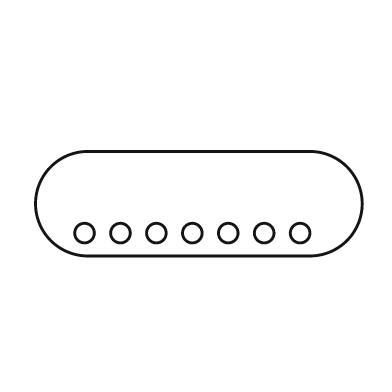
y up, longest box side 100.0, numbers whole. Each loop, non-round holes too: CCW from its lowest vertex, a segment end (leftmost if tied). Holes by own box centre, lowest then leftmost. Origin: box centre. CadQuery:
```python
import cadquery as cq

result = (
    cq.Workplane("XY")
    .moveTo(-34.0, -16.0)
    .lineTo(34.0, -16.0)
    .threePointArc((50.0, 0.0), (34.0, 16.0))
    .lineTo(-34.0, 16.0)
    .threePointArc((-50.0, 0.0), (-34.0, -16.0))
    .close()
    .moveTo(-35.0, -9.0)
    .circle(3.0)
    .moveTo(-24.0, -9.0)
    .circle(3.0)
    .moveTo(-13.0, -9.0)
    .circle(3.0)
    .moveTo(-2.0, -9.0)
    .circle(3.0)
    .moveTo(9.0, -9.0)
    .circle(3.0)
    .moveTo(20.0, -9.0)
    .circle(3.0)
    .moveTo(31.0, -9.0)
    .circle(3.0)
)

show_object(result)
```